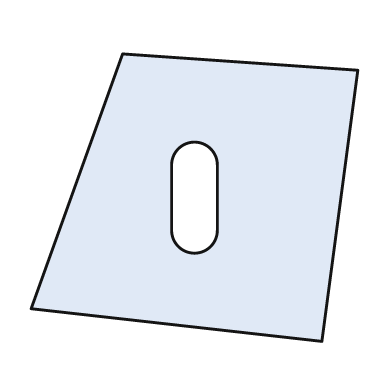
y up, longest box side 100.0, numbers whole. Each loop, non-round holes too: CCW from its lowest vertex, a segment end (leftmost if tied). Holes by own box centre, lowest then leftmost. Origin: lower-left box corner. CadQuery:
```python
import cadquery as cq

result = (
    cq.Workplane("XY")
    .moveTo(89.0, 0.0)
    .lineTo(100.0, 83.0)
    .lineTo(28.0, 88.0)
    .lineTo(0.0, 10.0)
    .close()
    .moveTo(43.0, 34.0)
    .threePointArc((50.0, 27.0), (57.0, 34.0))
    .lineTo(57.0, 54.0)
    .threePointArc((50.0, 61.0), (43.0, 54.0))
    .close()
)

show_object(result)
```